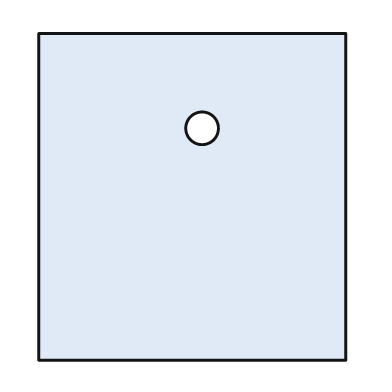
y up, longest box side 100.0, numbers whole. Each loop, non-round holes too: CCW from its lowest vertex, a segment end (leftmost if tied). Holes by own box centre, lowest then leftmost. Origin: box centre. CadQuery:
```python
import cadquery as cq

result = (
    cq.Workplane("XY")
    .moveTo(-47.0, -50.0)
    .lineTo(47.0, -50.0)
    .lineTo(47.0, 50.0)
    .lineTo(-47.0, 50.0)
    .close()
    .moveTo(3.0, 21.0)
    .circle(5.0)
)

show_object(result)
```